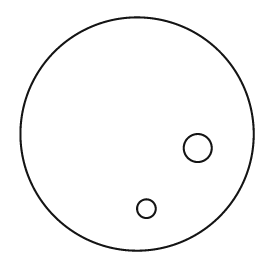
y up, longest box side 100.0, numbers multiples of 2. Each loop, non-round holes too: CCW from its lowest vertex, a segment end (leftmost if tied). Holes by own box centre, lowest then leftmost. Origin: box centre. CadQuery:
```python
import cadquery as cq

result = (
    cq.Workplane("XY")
    .moveTo(0.0, 0.0)
    .circle(50.0)
    .moveTo(4.0, -32.0)
    .circle(4.0)
    .moveTo(26.0, -6.0)
    .circle(6.0)
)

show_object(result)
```